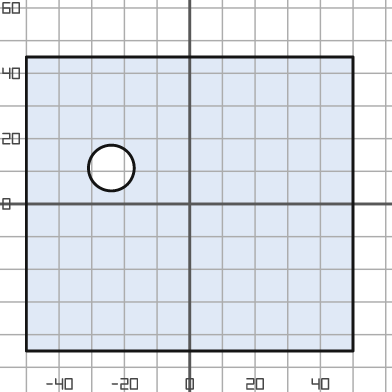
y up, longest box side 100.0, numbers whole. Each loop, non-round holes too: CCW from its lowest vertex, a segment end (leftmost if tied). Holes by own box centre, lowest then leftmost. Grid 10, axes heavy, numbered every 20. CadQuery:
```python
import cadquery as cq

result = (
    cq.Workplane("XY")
    .moveTo(-50.0, -45.0)
    .lineTo(50.0, -45.0)
    .lineTo(50.0, 45.0)
    .lineTo(-50.0, 45.0)
    .close()
    .moveTo(-24.0, 11.0)
    .circle(7.0)
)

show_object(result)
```